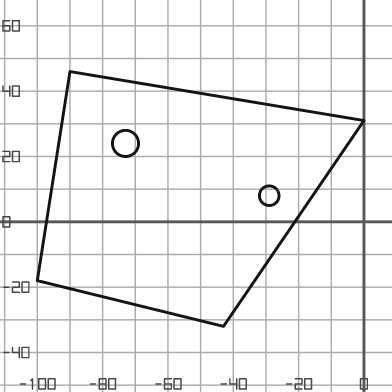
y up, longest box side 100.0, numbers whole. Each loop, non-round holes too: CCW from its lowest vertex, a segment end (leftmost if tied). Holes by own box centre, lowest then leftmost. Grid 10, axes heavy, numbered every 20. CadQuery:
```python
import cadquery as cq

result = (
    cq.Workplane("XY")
    .moveTo(-43.0, -32.0)
    .lineTo(0.0, 31.0)
    .lineTo(-90.0, 46.0)
    .lineTo(-100.0, -18.0)
    .close()
    .moveTo(-29.0, 8.0)
    .circle(3.0)
    .moveTo(-73.0, 24.0)
    .circle(4.0)
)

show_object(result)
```